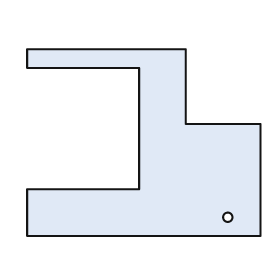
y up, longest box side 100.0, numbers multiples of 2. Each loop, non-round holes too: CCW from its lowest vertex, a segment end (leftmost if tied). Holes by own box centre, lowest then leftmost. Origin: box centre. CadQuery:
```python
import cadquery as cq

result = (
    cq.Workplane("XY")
    .moveTo(-50.0, -40.0)
    .lineTo(50.0, -40.0)
    .lineTo(50.0, 8.0)
    .lineTo(18.0, 8.0)
    .lineTo(18.0, 40.0)
    .lineTo(-50.0, 40.0)
    .lineTo(-50.0, 32.0)
    .lineTo(-2.0, 32.0)
    .lineTo(-2.0, -20.0)
    .lineTo(-50.0, -20.0)
    .close()
    .moveTo(36.0, -32.0)
    .circle(2.0)
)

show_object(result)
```